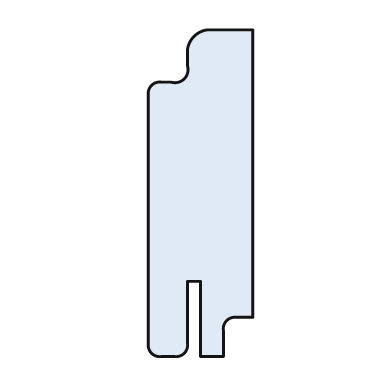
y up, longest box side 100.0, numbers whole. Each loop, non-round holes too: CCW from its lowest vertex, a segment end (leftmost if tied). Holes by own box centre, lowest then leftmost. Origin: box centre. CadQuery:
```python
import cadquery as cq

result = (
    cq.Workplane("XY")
    .moveTo(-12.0, -50.0)
    .lineTo(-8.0, -50.0)
    .threePointArc((-5.0, -49.0), (-4.0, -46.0))
    .lineTo(-4.0, -27.0)
    .lineTo(0.0, -27.0)
    .lineTo(0.0, -50.0)
    .lineTo(7.0, -50.0)
    .lineTo(7.0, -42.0)
    .threePointArc((8.0, -39.0), (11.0, -38.0))
    .lineTo(16.0, -38.0)
    .lineTo(16.0, 50.0)
    .lineTo(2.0, 50.0)
    .threePointArc((-2.0, 48.0), (-4.0, 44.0))
    .lineTo(-4.0, 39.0)
    .threePointArc((-5.0, 35.0), (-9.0, 34.0))
    .lineTo(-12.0, 34.0)
    .threePointArc((-15.0, 33.0), (-16.0, 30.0))
    .lineTo(-16.0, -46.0)
    .threePointArc((-15.0, -49.0), (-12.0, -50.0))
    .close()
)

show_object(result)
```